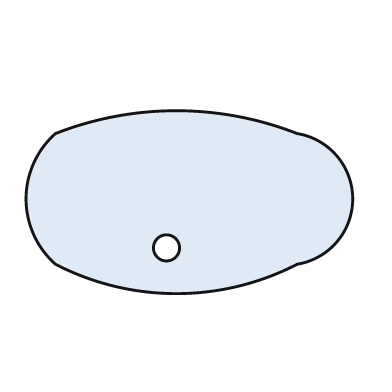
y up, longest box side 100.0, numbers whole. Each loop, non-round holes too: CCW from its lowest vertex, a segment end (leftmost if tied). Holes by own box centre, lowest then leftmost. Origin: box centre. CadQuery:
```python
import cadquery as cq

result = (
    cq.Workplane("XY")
    .moveTo(-41.0, -19.0)
    .threePointArc((-4.0, -28.0), (33.0, -19.0))
    .threePointArc((50.0, 1.0), (33.0, 21.0))
    .threePointArc((-4.0, 28.0), (-41.0, 21.0))
    .threePointArc((-50.0, 1.0), (-41.0, -19.0))
    .close()
    .moveTo(-7.0, -14.0)
    .circle(4.0)
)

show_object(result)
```